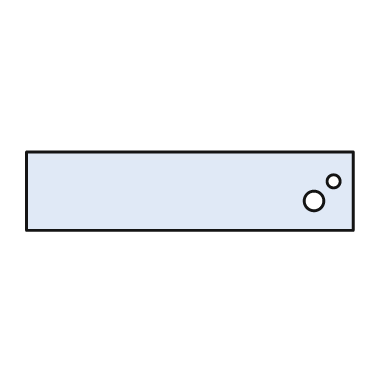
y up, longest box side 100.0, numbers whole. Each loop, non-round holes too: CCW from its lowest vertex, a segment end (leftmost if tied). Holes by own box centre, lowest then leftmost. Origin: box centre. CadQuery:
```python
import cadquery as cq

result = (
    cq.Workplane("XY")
    .moveTo(-50.0, -12.0)
    .lineTo(50.0, -12.0)
    .lineTo(50.0, 12.0)
    .lineTo(-50.0, 12.0)
    .close()
    .moveTo(38.0, -3.0)
    .circle(3.0)
    .moveTo(44.0, 3.0)
    .circle(2.0)
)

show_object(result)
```